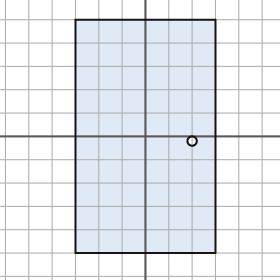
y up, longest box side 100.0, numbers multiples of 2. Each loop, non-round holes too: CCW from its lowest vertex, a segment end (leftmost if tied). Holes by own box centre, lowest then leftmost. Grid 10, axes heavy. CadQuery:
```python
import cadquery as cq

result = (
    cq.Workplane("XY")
    .moveTo(-30.0, -50.0)
    .lineTo(30.0, -50.0)
    .lineTo(30.0, 50.0)
    .lineTo(-30.0, 50.0)
    .close()
    .moveTo(20.0, -2.0)
    .circle(2.0)
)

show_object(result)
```